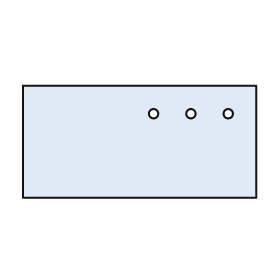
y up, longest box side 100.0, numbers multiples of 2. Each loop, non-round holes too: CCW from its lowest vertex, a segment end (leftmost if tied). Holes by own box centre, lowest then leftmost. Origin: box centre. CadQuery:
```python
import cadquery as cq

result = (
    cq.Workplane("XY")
    .moveTo(-50.0, -24.0)
    .lineTo(50.0, -24.0)
    .lineTo(50.0, 24.0)
    .lineTo(-50.0, 24.0)
    .close()
    .moveTo(6.0, 12.0)
    .circle(2.0)
    .moveTo(22.0, 12.0)
    .circle(2.0)
    .moveTo(38.0, 12.0)
    .circle(2.0)
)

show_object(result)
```